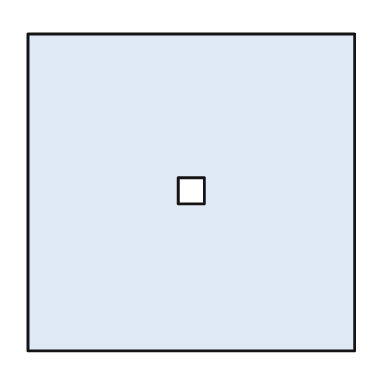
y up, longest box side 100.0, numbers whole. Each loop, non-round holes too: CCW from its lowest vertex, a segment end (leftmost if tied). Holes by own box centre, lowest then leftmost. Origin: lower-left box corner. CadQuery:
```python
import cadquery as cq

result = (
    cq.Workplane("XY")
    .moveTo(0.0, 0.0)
    .lineTo(100.0, 0.0)
    .lineTo(100.0, 97.0)
    .lineTo(0.0, 97.0)
    .close()
    .moveTo(46.0, 45.0)
    .lineTo(54.0, 45.0)
    .lineTo(54.0, 53.0)
    .lineTo(46.0, 53.0)
    .close()
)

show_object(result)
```